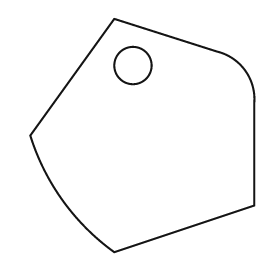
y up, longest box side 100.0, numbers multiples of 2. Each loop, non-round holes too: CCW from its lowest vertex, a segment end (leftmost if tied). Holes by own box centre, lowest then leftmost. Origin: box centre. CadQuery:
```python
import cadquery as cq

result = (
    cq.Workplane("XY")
    .moveTo(-12.0, -50.0)
    .lineTo(48.0, -30.0)
    .lineTo(48.0, 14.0)
    .threePointArc((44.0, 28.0), (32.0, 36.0))
    .lineTo(-12.0, 50.0)
    .lineTo(-48.0, 0.0)
    .threePointArc((-34.0, -28.0), (-12.0, -50.0))
    .close()
    .moveTo(-4.0, 30.0)
    .circle(8.0)
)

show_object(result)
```